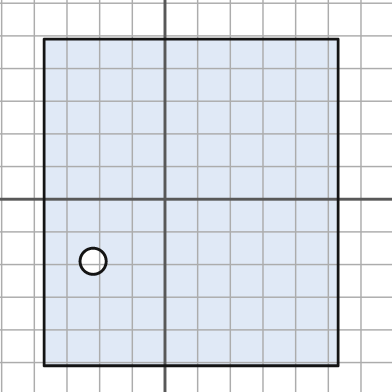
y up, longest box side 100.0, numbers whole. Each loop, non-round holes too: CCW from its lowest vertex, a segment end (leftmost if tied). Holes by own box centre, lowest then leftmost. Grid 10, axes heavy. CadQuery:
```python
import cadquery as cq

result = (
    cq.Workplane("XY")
    .moveTo(-37.0, -51.0)
    .lineTo(53.0, -51.0)
    .lineTo(53.0, 49.0)
    .lineTo(-37.0, 49.0)
    .close()
    .moveTo(-22.0, -19.0)
    .circle(4.0)
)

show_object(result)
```